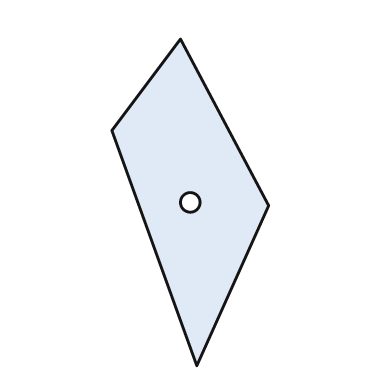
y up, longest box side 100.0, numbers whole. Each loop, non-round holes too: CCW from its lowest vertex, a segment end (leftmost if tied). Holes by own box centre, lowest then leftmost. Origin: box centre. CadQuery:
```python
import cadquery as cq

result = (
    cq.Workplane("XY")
    .moveTo(2.0, -50.0)
    .lineTo(24.0, -1.0)
    .lineTo(-3.0, 50.0)
    .lineTo(-24.0, 22.0)
    .close()
    .moveTo(0.0, 0.0)
    .circle(3.0)
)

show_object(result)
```